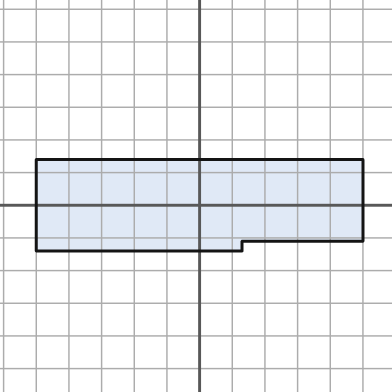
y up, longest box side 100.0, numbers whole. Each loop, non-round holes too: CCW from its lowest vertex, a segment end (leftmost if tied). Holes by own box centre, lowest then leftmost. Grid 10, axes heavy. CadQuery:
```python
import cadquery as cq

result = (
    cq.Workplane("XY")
    .moveTo(-50.0, -14.0)
    .lineTo(13.0, -14.0)
    .lineTo(13.0, -11.0)
    .lineTo(50.0, -11.0)
    .lineTo(50.0, 14.0)
    .lineTo(-50.0, 14.0)
    .close()
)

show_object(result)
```